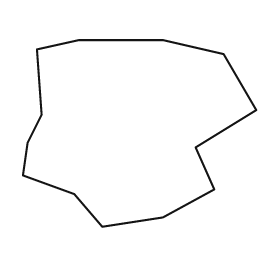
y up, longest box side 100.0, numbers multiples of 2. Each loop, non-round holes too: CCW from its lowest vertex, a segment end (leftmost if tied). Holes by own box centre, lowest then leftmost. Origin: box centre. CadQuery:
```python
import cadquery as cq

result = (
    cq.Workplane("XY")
    .moveTo(-16.0, -40.0)
    .lineTo(10.0, -36.0)
    .lineTo(32.0, -24.0)
    .lineTo(24.0, -6.0)
    .lineTo(50.0, 10.0)
    .lineTo(36.0, 34.0)
    .lineTo(10.0, 40.0)
    .lineTo(-26.0, 40.0)
    .lineTo(-44.0, 36.0)
    .lineTo(-42.0, 8.0)
    .lineTo(-48.0, -4.0)
    .lineTo(-50.0, -18.0)
    .lineTo(-28.0, -26.0)
    .close()
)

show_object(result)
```